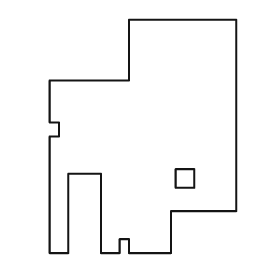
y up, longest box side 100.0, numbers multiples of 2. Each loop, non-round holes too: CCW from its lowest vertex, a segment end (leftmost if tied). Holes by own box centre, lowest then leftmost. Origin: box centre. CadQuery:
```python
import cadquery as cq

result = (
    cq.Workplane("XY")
    .moveTo(-40.0, -50.0)
    .lineTo(-32.0, -50.0)
    .lineTo(-32.0, -16.0)
    .lineTo(-18.0, -16.0)
    .lineTo(-18.0, -50.0)
    .lineTo(-10.0, -50.0)
    .lineTo(-10.0, -44.0)
    .lineTo(-6.0, -44.0)
    .lineTo(-6.0, -50.0)
    .lineTo(12.0, -50.0)
    .lineTo(12.0, -32.0)
    .lineTo(40.0, -32.0)
    .lineTo(40.0, 50.0)
    .lineTo(-6.0, 50.0)
    .lineTo(-6.0, 24.0)
    .lineTo(-40.0, 24.0)
    .lineTo(-40.0, 6.0)
    .lineTo(-36.0, 6.0)
    .lineTo(-36.0, 0.0)
    .lineTo(-40.0, 0.0)
    .close()
    .moveTo(14.0, -22.0)
    .lineTo(22.0, -22.0)
    .lineTo(22.0, -14.0)
    .lineTo(14.0, -14.0)
    .close()
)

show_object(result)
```